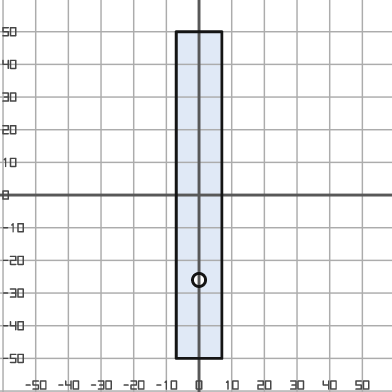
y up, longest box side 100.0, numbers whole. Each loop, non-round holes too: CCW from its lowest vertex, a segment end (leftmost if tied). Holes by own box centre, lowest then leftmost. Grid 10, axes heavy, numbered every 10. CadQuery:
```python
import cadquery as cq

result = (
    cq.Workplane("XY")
    .moveTo(-7.0, -50.0)
    .lineTo(7.0, -50.0)
    .lineTo(7.0, 50.0)
    .lineTo(-7.0, 50.0)
    .close()
    .moveTo(0.0, -26.0)
    .circle(2.0)
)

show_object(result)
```